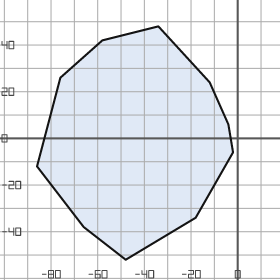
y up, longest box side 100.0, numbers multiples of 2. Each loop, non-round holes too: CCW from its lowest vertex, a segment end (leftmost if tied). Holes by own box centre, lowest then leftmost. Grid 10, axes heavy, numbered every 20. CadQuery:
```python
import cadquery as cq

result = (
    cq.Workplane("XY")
    .moveTo(-48.0, -52.0)
    .lineTo(-18.0, -34.0)
    .lineTo(-2.0, -6.0)
    .lineTo(-4.0, 6.0)
    .lineTo(-12.0, 24.0)
    .lineTo(-34.0, 48.0)
    .lineTo(-58.0, 42.0)
    .lineTo(-76.0, 26.0)
    .lineTo(-86.0, -12.0)
    .lineTo(-66.0, -38.0)
    .close()
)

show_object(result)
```